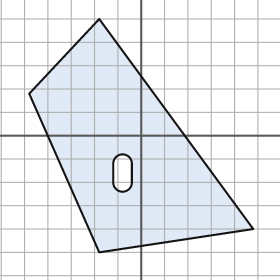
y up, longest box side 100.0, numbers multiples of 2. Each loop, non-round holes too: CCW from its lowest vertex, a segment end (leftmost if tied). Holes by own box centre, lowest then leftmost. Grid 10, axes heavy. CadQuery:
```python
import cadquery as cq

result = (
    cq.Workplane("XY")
    .moveTo(-18.0, -50.0)
    .lineTo(48.0, -40.0)
    .lineTo(-18.0, 50.0)
    .lineTo(-48.0, 18.0)
    .close()
    .moveTo(-12.0, -20.0)
    .threePointArc((-8.0, -24.0), (-4.0, -20.0))
    .lineTo(-4.0, -12.0)
    .threePointArc((-8.0, -8.0), (-12.0, -12.0))
    .close()
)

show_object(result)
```